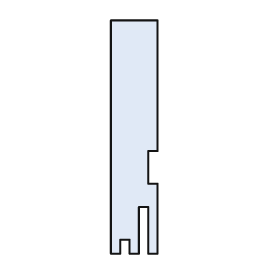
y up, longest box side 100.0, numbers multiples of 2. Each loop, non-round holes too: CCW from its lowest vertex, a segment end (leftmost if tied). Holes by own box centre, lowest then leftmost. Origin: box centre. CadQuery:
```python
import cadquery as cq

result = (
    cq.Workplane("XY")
    .moveTo(-10.0, -50.0)
    .lineTo(-6.0, -50.0)
    .lineTo(-6.0, -44.0)
    .lineTo(-2.0, -44.0)
    .lineTo(-2.0, -50.0)
    .lineTo(2.0, -50.0)
    .lineTo(2.0, -30.0)
    .lineTo(6.0, -30.0)
    .lineTo(6.0, -50.0)
    .lineTo(10.0, -50.0)
    .lineTo(10.0, -20.0)
    .lineTo(6.0, -20.0)
    .lineTo(6.0, -6.0)
    .lineTo(10.0, -6.0)
    .lineTo(10.0, 50.0)
    .lineTo(-10.0, 50.0)
    .close()
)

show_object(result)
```